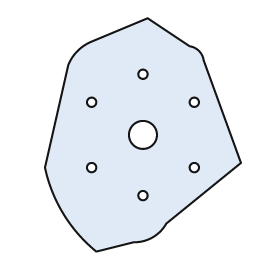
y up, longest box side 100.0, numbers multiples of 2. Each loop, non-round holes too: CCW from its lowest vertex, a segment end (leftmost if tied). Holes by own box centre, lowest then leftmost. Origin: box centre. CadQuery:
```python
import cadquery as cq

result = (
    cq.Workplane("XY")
    .moveTo(-20.0, -50.0)
    .lineTo(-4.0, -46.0)
    .threePointArc((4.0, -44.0), (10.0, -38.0))
    .lineTo(42.0, -12.0)
    .lineTo(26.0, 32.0)
    .threePointArc((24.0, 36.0), (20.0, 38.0))
    .lineTo(2.0, 50.0)
    .lineTo(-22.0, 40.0)
    .threePointArc((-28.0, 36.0), (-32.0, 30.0))
    .lineTo(-42.0, -14.0)
    .threePointArc((-34.0, -34.0), (-20.0, -50.0))
    .close()
    .moveTo(0.0, -26.0)
    .circle(2.0)
    .moveTo(-22.0, -14.0)
    .circle(2.0)
    .moveTo(22.0, -14.0)
    .circle(2.0)
    .moveTo(0.0, 0.0)
    .circle(6.0)
    .moveTo(-22.0, 14.0)
    .circle(2.0)
    .moveTo(22.0, 14.0)
    .circle(2.0)
    .moveTo(0.0, 26.0)
    .circle(2.0)
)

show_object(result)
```